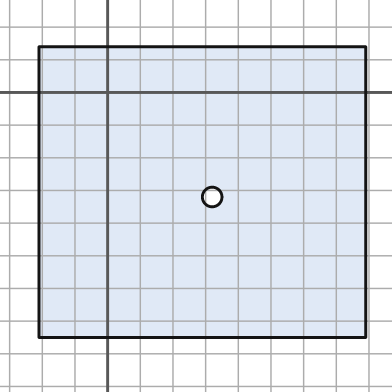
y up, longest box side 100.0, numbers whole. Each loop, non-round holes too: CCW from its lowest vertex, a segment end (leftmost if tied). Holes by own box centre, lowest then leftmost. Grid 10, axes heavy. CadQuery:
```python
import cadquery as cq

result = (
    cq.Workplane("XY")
    .moveTo(-21.0, -75.0)
    .lineTo(79.0, -75.0)
    .lineTo(79.0, 14.0)
    .lineTo(-21.0, 14.0)
    .close()
    .moveTo(32.0, -32.0)
    .circle(3.0)
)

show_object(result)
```